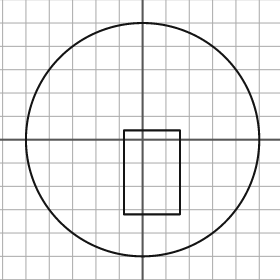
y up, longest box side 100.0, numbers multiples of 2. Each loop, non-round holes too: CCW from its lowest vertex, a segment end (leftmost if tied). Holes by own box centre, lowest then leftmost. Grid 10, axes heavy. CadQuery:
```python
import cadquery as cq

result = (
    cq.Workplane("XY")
    .moveTo(0.0, 0.0)
    .circle(50.0)
    .moveTo(-8.0, -32.0)
    .lineTo(16.0, -32.0)
    .lineTo(16.0, 4.0)
    .lineTo(-8.0, 4.0)
    .close()
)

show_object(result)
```